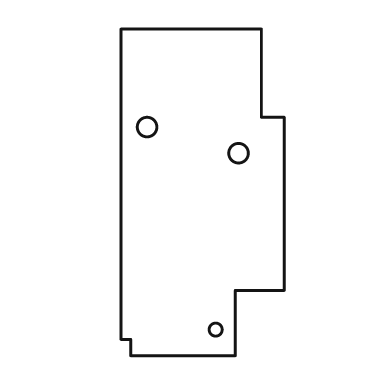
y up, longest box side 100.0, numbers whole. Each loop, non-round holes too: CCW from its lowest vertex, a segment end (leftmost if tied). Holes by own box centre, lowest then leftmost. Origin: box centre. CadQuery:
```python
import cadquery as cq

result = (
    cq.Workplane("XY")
    .moveTo(-22.0, -50.0)
    .lineTo(10.0, -50.0)
    .lineTo(10.0, -30.0)
    .lineTo(25.0, -30.0)
    .lineTo(25.0, 23.0)
    .lineTo(18.0, 23.0)
    .lineTo(18.0, 50.0)
    .lineTo(-25.0, 50.0)
    .lineTo(-25.0, -45.0)
    .lineTo(-22.0, -45.0)
    .close()
    .moveTo(4.0, -42.0)
    .circle(2.0)
    .moveTo(11.0, 12.0)
    .circle(3.0)
    .moveTo(-17.0, 20.0)
    .circle(3.0)
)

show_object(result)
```